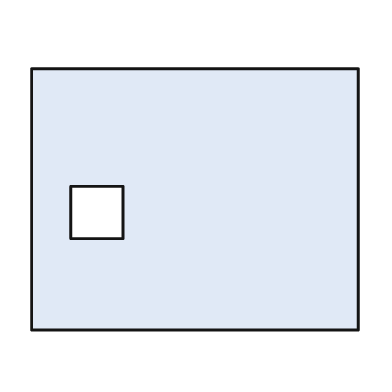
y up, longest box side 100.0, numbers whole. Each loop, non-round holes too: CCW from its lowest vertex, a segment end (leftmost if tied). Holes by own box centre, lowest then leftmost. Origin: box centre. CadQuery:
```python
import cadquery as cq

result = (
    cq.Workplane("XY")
    .moveTo(-50.0, -40.0)
    .lineTo(50.0, -40.0)
    .lineTo(50.0, 40.0)
    .lineTo(-50.0, 40.0)
    .close()
    .moveTo(-38.0, -12.0)
    .lineTo(-22.0, -12.0)
    .lineTo(-22.0, 4.0)
    .lineTo(-38.0, 4.0)
    .close()
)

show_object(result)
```